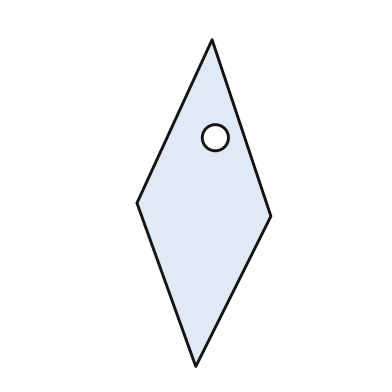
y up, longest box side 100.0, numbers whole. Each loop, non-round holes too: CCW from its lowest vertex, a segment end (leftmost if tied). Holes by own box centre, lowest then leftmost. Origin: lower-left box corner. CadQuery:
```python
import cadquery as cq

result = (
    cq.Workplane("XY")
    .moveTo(18.0, 0.0)
    .lineTo(41.0, 46.0)
    .lineTo(23.0, 100.0)
    .lineTo(0.0, 50.0)
    .close()
    .moveTo(24.0, 70.0)
    .circle(4.0)
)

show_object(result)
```